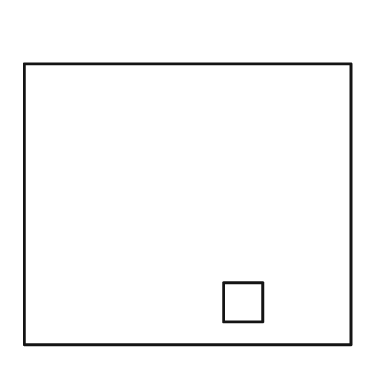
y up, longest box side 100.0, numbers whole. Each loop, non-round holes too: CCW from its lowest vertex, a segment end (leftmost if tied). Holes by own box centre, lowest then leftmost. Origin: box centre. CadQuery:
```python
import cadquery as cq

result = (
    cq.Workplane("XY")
    .moveTo(-50.0, -43.0)
    .lineTo(50.0, -43.0)
    .lineTo(50.0, 43.0)
    .lineTo(-50.0, 43.0)
    .close()
    .moveTo(11.0, -36.0)
    .lineTo(23.0, -36.0)
    .lineTo(23.0, -24.0)
    .lineTo(11.0, -24.0)
    .close()
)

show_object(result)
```